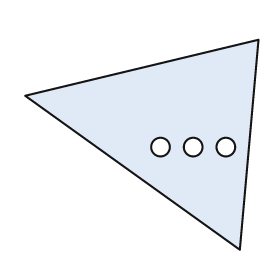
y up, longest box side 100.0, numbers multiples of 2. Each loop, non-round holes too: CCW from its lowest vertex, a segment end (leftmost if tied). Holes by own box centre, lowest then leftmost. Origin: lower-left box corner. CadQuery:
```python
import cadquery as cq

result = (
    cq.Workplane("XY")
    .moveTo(92.0, 0.0)
    .lineTo(100.0, 90.0)
    .lineTo(0.0, 66.0)
    .close()
    .moveTo(58.0, 44.0)
    .circle(4.0)
    .moveTo(72.0, 44.0)
    .circle(4.0)
    .moveTo(86.0, 44.0)
    .circle(4.0)
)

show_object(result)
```